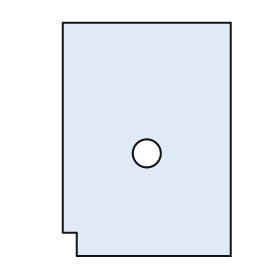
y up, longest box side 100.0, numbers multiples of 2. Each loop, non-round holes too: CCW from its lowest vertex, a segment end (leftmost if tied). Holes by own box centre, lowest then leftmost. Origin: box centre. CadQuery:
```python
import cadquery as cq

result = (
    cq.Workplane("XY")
    .moveTo(-30.0, -50.0)
    .lineTo(36.0, -50.0)
    .lineTo(36.0, 50.0)
    .lineTo(-36.0, 50.0)
    .lineTo(-36.0, -40.0)
    .lineTo(-30.0, -40.0)
    .close()
    .moveTo(0.0, -6.0)
    .circle(6.0)
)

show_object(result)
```